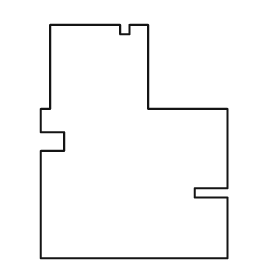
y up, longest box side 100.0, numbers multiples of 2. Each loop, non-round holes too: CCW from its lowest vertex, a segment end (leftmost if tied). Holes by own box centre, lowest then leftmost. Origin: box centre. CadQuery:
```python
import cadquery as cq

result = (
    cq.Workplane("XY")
    .moveTo(-40.0, -50.0)
    .lineTo(40.0, -50.0)
    .lineTo(40.0, -24.0)
    .lineTo(26.0, -24.0)
    .lineTo(26.0, -20.0)
    .lineTo(40.0, -20.0)
    .lineTo(40.0, 14.0)
    .lineTo(6.0, 14.0)
    .lineTo(6.0, 50.0)
    .lineTo(-2.0, 50.0)
    .lineTo(-2.0, 46.0)
    .lineTo(-6.0, 46.0)
    .lineTo(-6.0, 50.0)
    .lineTo(-36.0, 50.0)
    .lineTo(-36.0, 14.0)
    .lineTo(-40.0, 14.0)
    .lineTo(-40.0, 4.0)
    .lineTo(-30.0, 4.0)
    .lineTo(-30.0, -4.0)
    .lineTo(-40.0, -4.0)
    .close()
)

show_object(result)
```